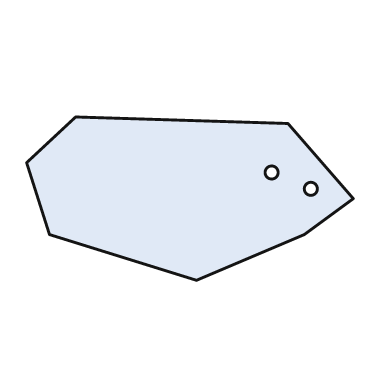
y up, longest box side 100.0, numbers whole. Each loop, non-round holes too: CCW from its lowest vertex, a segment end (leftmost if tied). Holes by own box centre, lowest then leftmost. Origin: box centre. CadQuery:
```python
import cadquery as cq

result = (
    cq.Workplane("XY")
    .moveTo(2.0, -25.0)
    .lineTo(35.0, -11.0)
    .lineTo(50.0, 0.0)
    .lineTo(30.0, 23.0)
    .lineTo(-35.0, 25.0)
    .lineTo(-50.0, 11.0)
    .lineTo(-43.0, -11.0)
    .close()
    .moveTo(37.0, 3.0)
    .circle(2.0)
    .moveTo(25.0, 8.0)
    .circle(2.0)
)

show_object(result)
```